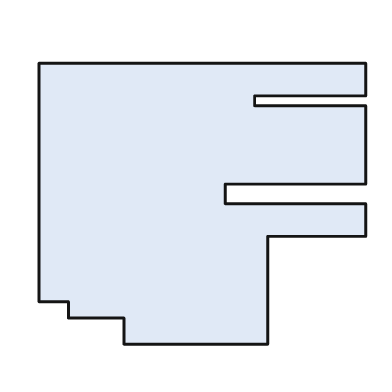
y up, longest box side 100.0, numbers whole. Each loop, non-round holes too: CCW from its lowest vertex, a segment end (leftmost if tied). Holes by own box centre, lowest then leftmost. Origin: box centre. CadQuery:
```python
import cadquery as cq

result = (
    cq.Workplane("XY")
    .moveTo(-24.0, -43.0)
    .lineTo(20.0, -43.0)
    .lineTo(20.0, -10.0)
    .lineTo(50.0, -10.0)
    .lineTo(50.0, 0.0)
    .lineTo(7.0, 0.0)
    .lineTo(7.0, 6.0)
    .lineTo(50.0, 6.0)
    .lineTo(50.0, 30.0)
    .lineTo(16.0, 30.0)
    .lineTo(16.0, 33.0)
    .lineTo(50.0, 33.0)
    .lineTo(50.0, 43.0)
    .lineTo(-50.0, 43.0)
    .lineTo(-50.0, -30.0)
    .lineTo(-41.0, -30.0)
    .lineTo(-41.0, -35.0)
    .lineTo(-24.0, -35.0)
    .close()
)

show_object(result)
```